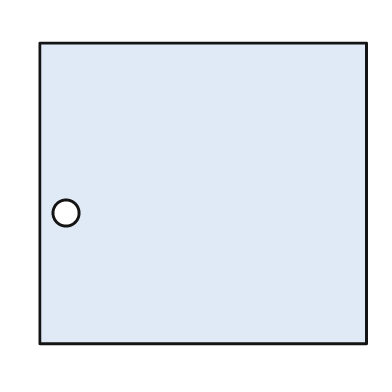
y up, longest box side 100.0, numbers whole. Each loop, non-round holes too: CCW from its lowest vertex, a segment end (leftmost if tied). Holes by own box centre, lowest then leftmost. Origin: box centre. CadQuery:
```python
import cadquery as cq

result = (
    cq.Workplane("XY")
    .moveTo(-50.0, -46.0)
    .lineTo(50.0, -46.0)
    .lineTo(50.0, 46.0)
    .lineTo(-50.0, 46.0)
    .close()
    .moveTo(-42.0, -6.0)
    .circle(4.0)
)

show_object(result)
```